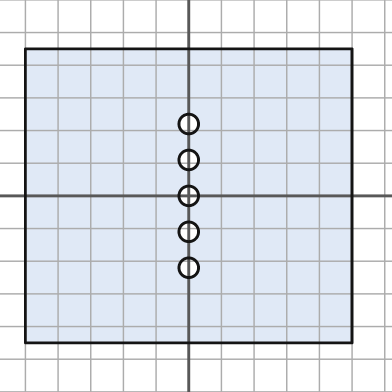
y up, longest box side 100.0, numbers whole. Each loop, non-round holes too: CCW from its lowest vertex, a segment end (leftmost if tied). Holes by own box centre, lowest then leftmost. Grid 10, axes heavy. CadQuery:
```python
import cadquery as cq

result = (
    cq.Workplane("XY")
    .moveTo(-50.0, -45.0)
    .lineTo(50.0, -45.0)
    .lineTo(50.0, 45.0)
    .lineTo(-50.0, 45.0)
    .close()
    .moveTo(0.0, -22.0)
    .circle(3.0)
    .moveTo(0.0, -11.0)
    .circle(3.0)
    .moveTo(0.0, 0.0)
    .circle(3.0)
    .moveTo(0.0, 11.0)
    .circle(3.0)
    .moveTo(0.0, 22.0)
    .circle(3.0)
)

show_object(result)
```